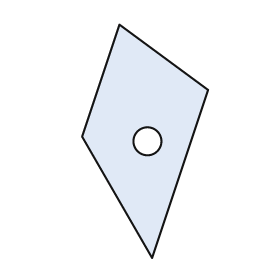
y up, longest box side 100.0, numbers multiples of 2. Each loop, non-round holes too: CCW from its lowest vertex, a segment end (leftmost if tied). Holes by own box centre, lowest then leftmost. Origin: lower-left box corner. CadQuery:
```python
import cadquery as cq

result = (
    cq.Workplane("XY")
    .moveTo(30.0, 0.0)
    .lineTo(54.0, 72.0)
    .lineTo(16.0, 100.0)
    .lineTo(0.0, 52.0)
    .close()
    .moveTo(28.0, 50.0)
    .circle(6.0)
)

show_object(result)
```